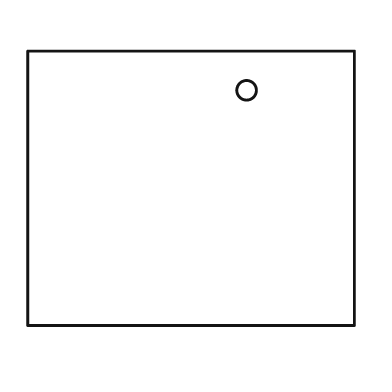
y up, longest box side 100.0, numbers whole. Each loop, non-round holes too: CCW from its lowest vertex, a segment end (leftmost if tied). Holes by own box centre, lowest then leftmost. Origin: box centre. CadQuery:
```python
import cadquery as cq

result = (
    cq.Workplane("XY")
    .moveTo(-50.0, -42.0)
    .lineTo(50.0, -42.0)
    .lineTo(50.0, 42.0)
    .lineTo(-50.0, 42.0)
    .close()
    .moveTo(17.0, 30.0)
    .circle(3.0)
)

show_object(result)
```